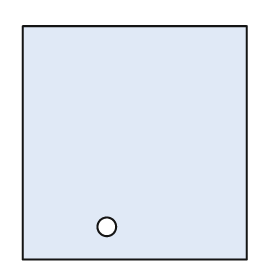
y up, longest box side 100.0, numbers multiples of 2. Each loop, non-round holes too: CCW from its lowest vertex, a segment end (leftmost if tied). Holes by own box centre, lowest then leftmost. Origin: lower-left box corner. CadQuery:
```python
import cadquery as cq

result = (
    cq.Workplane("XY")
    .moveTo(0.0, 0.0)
    .lineTo(96.0, 0.0)
    .lineTo(96.0, 100.0)
    .lineTo(0.0, 100.0)
    .close()
    .moveTo(36.0, 14.0)
    .circle(4.0)
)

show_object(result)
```